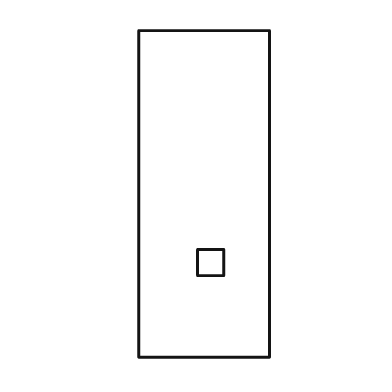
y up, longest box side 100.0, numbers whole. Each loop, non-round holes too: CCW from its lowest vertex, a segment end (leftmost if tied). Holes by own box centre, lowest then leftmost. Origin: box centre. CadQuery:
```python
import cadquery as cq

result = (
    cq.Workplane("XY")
    .moveTo(-20.0, -50.0)
    .lineTo(20.0, -50.0)
    .lineTo(20.0, 50.0)
    .lineTo(-20.0, 50.0)
    .close()
    .moveTo(-2.0, -25.0)
    .lineTo(6.0, -25.0)
    .lineTo(6.0, -17.0)
    .lineTo(-2.0, -17.0)
    .close()
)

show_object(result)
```